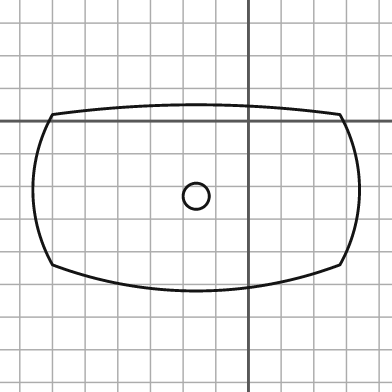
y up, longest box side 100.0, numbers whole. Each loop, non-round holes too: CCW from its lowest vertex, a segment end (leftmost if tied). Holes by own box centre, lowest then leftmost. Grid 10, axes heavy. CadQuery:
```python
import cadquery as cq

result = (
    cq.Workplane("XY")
    .moveTo(-60.0, -44.0)
    .threePointArc((-16.0, -52.0), (28.0, -44.0))
    .threePointArc((34.0, -21.0), (28.0, 2.0))
    .threePointArc((-16.0, 5.0), (-60.0, 2.0))
    .threePointArc((-66.0, -21.0), (-60.0, -44.0))
    .close()
    .moveTo(-16.0, -23.0)
    .circle(4.0)
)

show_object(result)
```